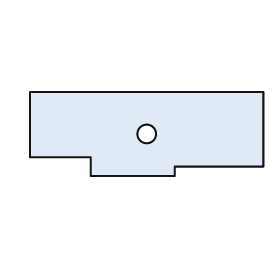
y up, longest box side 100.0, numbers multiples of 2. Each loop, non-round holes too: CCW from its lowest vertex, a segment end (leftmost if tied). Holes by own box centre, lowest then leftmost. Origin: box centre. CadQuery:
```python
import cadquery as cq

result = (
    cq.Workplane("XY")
    .moveTo(-24.0, -18.0)
    .lineTo(12.0, -18.0)
    .lineTo(12.0, -14.0)
    .lineTo(50.0, -14.0)
    .lineTo(50.0, 18.0)
    .lineTo(-50.0, 18.0)
    .lineTo(-50.0, -10.0)
    .lineTo(-24.0, -10.0)
    .close()
    .moveTo(0.0, 0.0)
    .circle(4.0)
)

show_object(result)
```